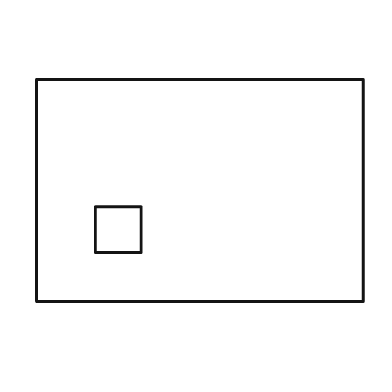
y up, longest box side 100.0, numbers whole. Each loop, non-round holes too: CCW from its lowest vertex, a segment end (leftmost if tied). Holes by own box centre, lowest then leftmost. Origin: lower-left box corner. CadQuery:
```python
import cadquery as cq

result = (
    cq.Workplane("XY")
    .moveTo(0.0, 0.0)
    .lineTo(100.0, 0.0)
    .lineTo(100.0, 68.0)
    .lineTo(0.0, 68.0)
    .close()
    .moveTo(18.0, 15.0)
    .lineTo(32.0, 15.0)
    .lineTo(32.0, 29.0)
    .lineTo(18.0, 29.0)
    .close()
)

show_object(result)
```